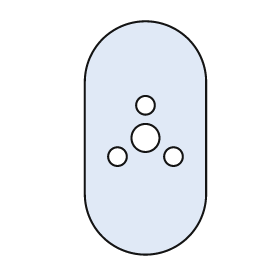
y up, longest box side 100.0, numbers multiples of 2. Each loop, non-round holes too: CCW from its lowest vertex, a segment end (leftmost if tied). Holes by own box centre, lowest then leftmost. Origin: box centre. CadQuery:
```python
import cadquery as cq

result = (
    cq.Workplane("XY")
    .moveTo(-26.0, -24.0)
    .threePointArc((0.0, -50.0), (26.0, -24.0))
    .lineTo(26.0, 24.0)
    .threePointArc((0.0, 50.0), (-26.0, 24.0))
    .close()
    .moveTo(-12.0, -8.0)
    .circle(4.0)
    .moveTo(12.0, -8.0)
    .circle(4.0)
    .moveTo(0.0, 0.0)
    .circle(6.0)
    .moveTo(0.0, 14.0)
    .circle(4.0)
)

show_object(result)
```